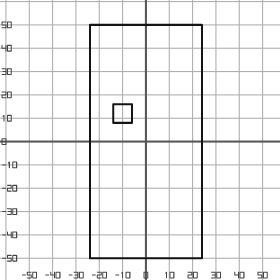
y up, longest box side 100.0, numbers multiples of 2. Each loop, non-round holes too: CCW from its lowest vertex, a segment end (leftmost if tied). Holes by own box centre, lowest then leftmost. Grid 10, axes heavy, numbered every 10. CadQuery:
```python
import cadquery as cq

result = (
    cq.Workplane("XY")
    .moveTo(-24.0, -50.0)
    .lineTo(24.0, -50.0)
    .lineTo(24.0, 50.0)
    .lineTo(-24.0, 50.0)
    .close()
    .moveTo(-14.0, 8.0)
    .lineTo(-6.0, 8.0)
    .lineTo(-6.0, 16.0)
    .lineTo(-14.0, 16.0)
    .close()
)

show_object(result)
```